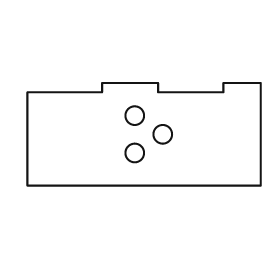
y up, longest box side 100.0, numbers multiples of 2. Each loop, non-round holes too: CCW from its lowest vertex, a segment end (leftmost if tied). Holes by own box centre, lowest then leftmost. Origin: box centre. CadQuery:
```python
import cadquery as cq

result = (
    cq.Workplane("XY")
    .moveTo(-50.0, -22.0)
    .lineTo(50.0, -22.0)
    .lineTo(50.0, 22.0)
    .lineTo(34.0, 22.0)
    .lineTo(34.0, 18.0)
    .lineTo(6.0, 18.0)
    .lineTo(6.0, 22.0)
    .lineTo(-18.0, 22.0)
    .lineTo(-18.0, 18.0)
    .lineTo(-50.0, 18.0)
    .close()
    .moveTo(-4.0, -8.0)
    .circle(4.0)
    .moveTo(8.0, 0.0)
    .circle(4.0)
    .moveTo(-4.0, 8.0)
    .circle(4.0)
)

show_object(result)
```